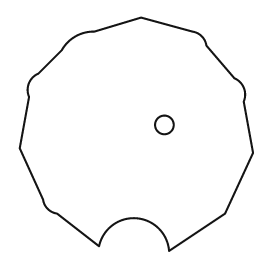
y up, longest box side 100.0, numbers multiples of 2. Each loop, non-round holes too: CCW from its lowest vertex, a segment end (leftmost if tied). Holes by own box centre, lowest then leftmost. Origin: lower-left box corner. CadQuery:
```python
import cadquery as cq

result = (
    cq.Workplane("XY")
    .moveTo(64.0, 0.0)
    .lineTo(88.0, 16.0)
    .lineTo(100.0, 42.0)
    .lineTo(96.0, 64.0)
    .threePointArc((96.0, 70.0), (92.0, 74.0))
    .lineTo(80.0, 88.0)
    .threePointArc((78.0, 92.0), (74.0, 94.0))
    .lineTo(52.0, 100.0)
    .lineTo(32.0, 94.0)
    .threePointArc((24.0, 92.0), (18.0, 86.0))
    .lineTo(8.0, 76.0)
    .threePointArc((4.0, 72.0), (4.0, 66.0))
    .lineTo(0.0, 44.0)
    .lineTo(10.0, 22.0)
    .threePointArc((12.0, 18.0), (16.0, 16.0))
    .lineTo(34.0, 2.0)
    .threePointArc((50.0, 14.0), (64.0, 0.0))
    .close()
    .moveTo(62.0, 54.0)
    .circle(4.0)
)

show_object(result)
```